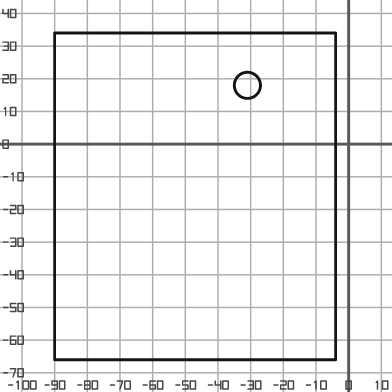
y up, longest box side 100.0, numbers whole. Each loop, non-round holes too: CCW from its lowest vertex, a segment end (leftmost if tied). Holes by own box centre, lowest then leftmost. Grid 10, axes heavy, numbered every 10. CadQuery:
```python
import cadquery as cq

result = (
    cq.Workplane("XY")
    .moveTo(-90.0, -66.0)
    .lineTo(-4.0, -66.0)
    .lineTo(-4.0, 34.0)
    .lineTo(-90.0, 34.0)
    .close()
    .moveTo(-31.0, 18.0)
    .circle(4.0)
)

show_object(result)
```